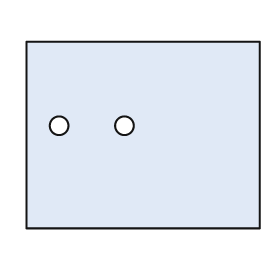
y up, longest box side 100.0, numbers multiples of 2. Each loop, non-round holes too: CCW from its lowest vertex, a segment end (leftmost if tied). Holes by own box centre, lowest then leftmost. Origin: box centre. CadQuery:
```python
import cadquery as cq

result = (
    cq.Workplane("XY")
    .moveTo(-50.0, -40.0)
    .lineTo(50.0, -40.0)
    .lineTo(50.0, 40.0)
    .lineTo(-50.0, 40.0)
    .close()
    .moveTo(-36.0, 4.0)
    .circle(4.0)
    .moveTo(-8.0, 4.0)
    .circle(4.0)
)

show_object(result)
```